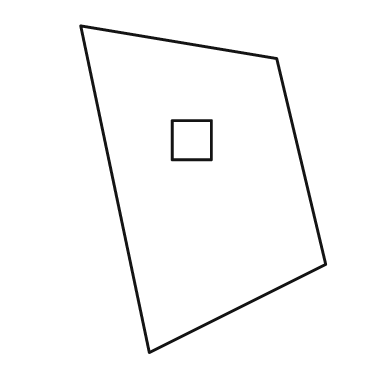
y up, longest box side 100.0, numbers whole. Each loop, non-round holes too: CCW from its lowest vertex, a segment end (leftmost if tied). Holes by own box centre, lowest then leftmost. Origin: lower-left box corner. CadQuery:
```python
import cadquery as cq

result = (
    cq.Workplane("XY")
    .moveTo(21.0, 0.0)
    .lineTo(75.0, 27.0)
    .lineTo(60.0, 90.0)
    .lineTo(0.0, 100.0)
    .close()
    .moveTo(28.0, 59.0)
    .lineTo(40.0, 59.0)
    .lineTo(40.0, 71.0)
    .lineTo(28.0, 71.0)
    .close()
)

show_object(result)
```